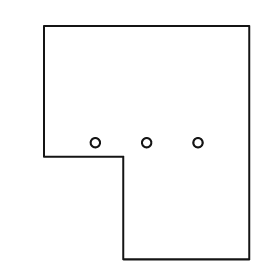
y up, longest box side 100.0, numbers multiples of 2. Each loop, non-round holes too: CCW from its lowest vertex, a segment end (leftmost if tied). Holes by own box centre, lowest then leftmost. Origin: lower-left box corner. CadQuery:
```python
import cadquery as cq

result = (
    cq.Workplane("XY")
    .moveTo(34.0, 0.0)
    .lineTo(88.0, 0.0)
    .lineTo(88.0, 100.0)
    .lineTo(0.0, 100.0)
    .lineTo(0.0, 44.0)
    .lineTo(34.0, 44.0)
    .close()
    .moveTo(22.0, 50.0)
    .circle(2.0)
    .moveTo(44.0, 50.0)
    .circle(2.0)
    .moveTo(66.0, 50.0)
    .circle(2.0)
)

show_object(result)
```